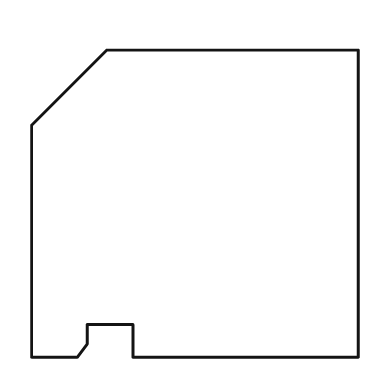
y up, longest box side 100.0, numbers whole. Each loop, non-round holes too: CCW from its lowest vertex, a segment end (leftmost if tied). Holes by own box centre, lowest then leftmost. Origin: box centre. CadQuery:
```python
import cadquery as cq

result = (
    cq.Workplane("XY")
    .moveTo(-50.0, -47.0)
    .lineTo(-36.0, -47.0)
    .lineTo(-33.0, -43.0)
    .lineTo(-33.0, -37.0)
    .lineTo(-19.0, -37.0)
    .lineTo(-19.0, -47.0)
    .lineTo(50.0, -47.0)
    .lineTo(50.0, 47.0)
    .lineTo(-27.0, 47.0)
    .lineTo(-50.0, 24.0)
    .close()
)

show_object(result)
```